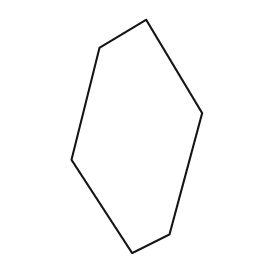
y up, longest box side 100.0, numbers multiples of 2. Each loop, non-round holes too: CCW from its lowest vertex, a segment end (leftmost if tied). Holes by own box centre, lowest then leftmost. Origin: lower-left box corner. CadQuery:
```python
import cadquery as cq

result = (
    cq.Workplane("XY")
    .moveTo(26.0, 0.0)
    .lineTo(42.0, 8.0)
    .lineTo(56.0, 60.0)
    .lineTo(32.0, 100.0)
    .lineTo(12.0, 88.0)
    .lineTo(0.0, 40.0)
    .close()
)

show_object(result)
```